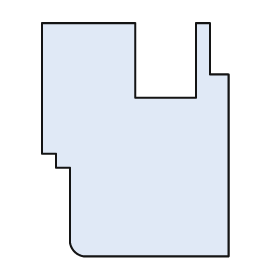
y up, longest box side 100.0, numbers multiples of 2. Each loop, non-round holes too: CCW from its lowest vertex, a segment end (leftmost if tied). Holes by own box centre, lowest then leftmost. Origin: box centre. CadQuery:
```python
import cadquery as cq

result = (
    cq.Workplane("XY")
    .moveTo(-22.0, -50.0)
    .lineTo(40.0, -50.0)
    .lineTo(40.0, 28.0)
    .lineTo(32.0, 28.0)
    .lineTo(32.0, 50.0)
    .lineTo(26.0, 50.0)
    .lineTo(26.0, 18.0)
    .lineTo(0.0, 18.0)
    .lineTo(0.0, 50.0)
    .lineTo(-40.0, 50.0)
    .lineTo(-40.0, -6.0)
    .lineTo(-34.0, -6.0)
    .lineTo(-34.0, -12.0)
    .lineTo(-28.0, -12.0)
    .lineTo(-28.0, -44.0)
    .threePointArc((-26.0, -48.0), (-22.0, -50.0))
    .close()
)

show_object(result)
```